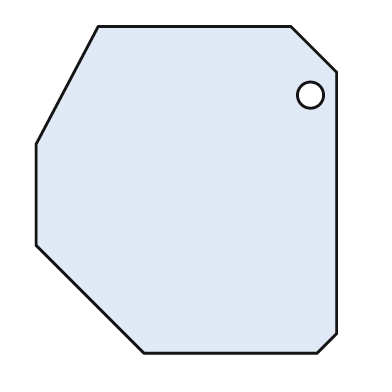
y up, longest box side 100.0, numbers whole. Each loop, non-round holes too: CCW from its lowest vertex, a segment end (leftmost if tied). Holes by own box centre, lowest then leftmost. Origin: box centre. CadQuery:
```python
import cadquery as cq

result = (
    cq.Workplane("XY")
    .moveTo(-13.0, -50.0)
    .lineTo(40.0, -50.0)
    .lineTo(46.0, -44.0)
    .lineTo(46.0, 36.0)
    .lineTo(32.0, 50.0)
    .lineTo(-27.0, 50.0)
    .lineTo(-46.0, 14.0)
    .lineTo(-46.0, -17.0)
    .close()
    .moveTo(38.0, 29.0)
    .circle(4.0)
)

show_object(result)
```